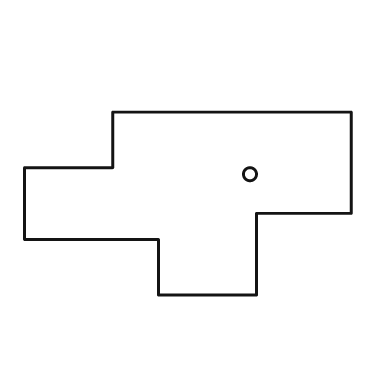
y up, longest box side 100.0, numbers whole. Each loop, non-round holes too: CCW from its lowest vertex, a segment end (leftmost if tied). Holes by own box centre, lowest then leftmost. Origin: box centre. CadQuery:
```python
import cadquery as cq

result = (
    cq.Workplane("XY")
    .moveTo(-9.0, -28.0)
    .lineTo(21.0, -28.0)
    .lineTo(21.0, -3.0)
    .lineTo(50.0, -3.0)
    .lineTo(50.0, 28.0)
    .lineTo(-23.0, 28.0)
    .lineTo(-23.0, 11.0)
    .lineTo(-50.0, 11.0)
    .lineTo(-50.0, -11.0)
    .lineTo(-9.0, -11.0)
    .close()
    .moveTo(19.0, 9.0)
    .circle(2.0)
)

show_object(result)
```